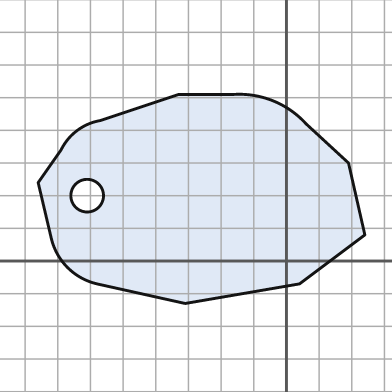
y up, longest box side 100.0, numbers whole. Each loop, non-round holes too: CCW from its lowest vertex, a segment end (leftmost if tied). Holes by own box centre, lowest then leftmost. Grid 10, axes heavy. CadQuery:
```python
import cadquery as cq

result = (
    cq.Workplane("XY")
    .moveTo(-31.0, -13.0)
    .lineTo(4.0, -7.0)
    .lineTo(24.0, 8.0)
    .lineTo(19.0, 30.0)
    .lineTo(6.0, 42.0)
    .threePointArc((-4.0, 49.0), (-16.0, 51.0))
    .lineTo(-33.0, 51.0)
    .lineTo(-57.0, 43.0)
    .threePointArc((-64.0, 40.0), (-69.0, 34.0))
    .lineTo(-76.0, 24.0)
    .lineTo(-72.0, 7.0)
    .threePointArc((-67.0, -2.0), (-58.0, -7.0))
    .close()
    .moveTo(-61.0, 20.0)
    .circle(5.0)
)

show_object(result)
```